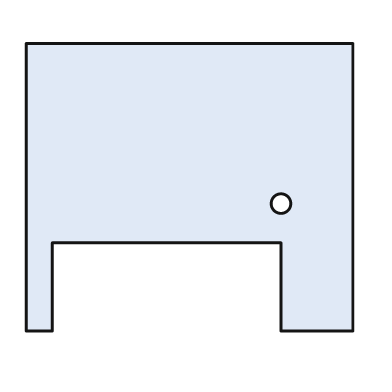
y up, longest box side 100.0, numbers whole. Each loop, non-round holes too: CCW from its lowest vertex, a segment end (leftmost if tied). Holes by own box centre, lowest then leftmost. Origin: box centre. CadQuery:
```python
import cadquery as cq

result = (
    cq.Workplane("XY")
    .moveTo(-50.0, -44.0)
    .lineTo(-42.0, -44.0)
    .lineTo(-42.0, -17.0)
    .lineTo(28.0, -17.0)
    .lineTo(28.0, -44.0)
    .lineTo(50.0, -44.0)
    .lineTo(50.0, 44.0)
    .lineTo(-50.0, 44.0)
    .close()
    .moveTo(28.0, -5.0)
    .circle(3.0)
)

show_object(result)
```